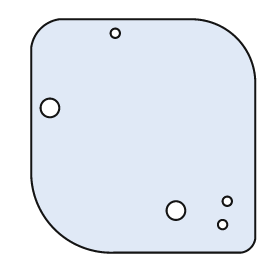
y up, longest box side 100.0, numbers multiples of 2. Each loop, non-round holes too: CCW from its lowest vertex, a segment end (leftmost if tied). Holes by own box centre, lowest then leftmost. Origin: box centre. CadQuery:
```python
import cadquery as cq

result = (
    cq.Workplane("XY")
    .moveTo(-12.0, -50.0)
    .lineTo(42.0, -50.0)
    .threePointArc((46.0, -48.0), (48.0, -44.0))
    .lineTo(48.0, 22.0)
    .threePointArc((40.0, 42.0), (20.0, 50.0))
    .lineTo(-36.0, 50.0)
    .threePointArc((-44.0, 46.0), (-48.0, 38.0))
    .lineTo(-48.0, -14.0)
    .threePointArc((-38.0, -40.0), (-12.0, -50.0))
    .close()
    .moveTo(34.0, -38.0)
    .circle(2.0)
    .moveTo(14.0, -32.0)
    .circle(4.0)
    .moveTo(36.0, -28.0)
    .circle(2.0)
    .moveTo(-40.0, 12.0)
    .circle(4.0)
    .moveTo(-12.0, 44.0)
    .circle(2.0)
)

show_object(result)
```